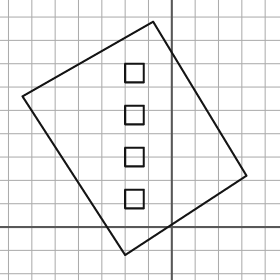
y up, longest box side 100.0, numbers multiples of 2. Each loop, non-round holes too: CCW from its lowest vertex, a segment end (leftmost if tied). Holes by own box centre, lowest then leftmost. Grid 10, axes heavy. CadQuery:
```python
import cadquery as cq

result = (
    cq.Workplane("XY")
    .moveTo(-20.0, -12.0)
    .lineTo(32.0, 22.0)
    .lineTo(-8.0, 88.0)
    .lineTo(-64.0, 56.0)
    .close()
    .moveTo(-20.0, 8.0)
    .lineTo(-12.0, 8.0)
    .lineTo(-12.0, 16.0)
    .lineTo(-20.0, 16.0)
    .close()
    .moveTo(-20.0, 26.0)
    .lineTo(-12.0, 26.0)
    .lineTo(-12.0, 34.0)
    .lineTo(-20.0, 34.0)
    .close()
    .moveTo(-20.0, 44.0)
    .lineTo(-12.0, 44.0)
    .lineTo(-12.0, 52.0)
    .lineTo(-20.0, 52.0)
    .close()
    .moveTo(-20.0, 62.0)
    .lineTo(-12.0, 62.0)
    .lineTo(-12.0, 70.0)
    .lineTo(-20.0, 70.0)
    .close()
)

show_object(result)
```